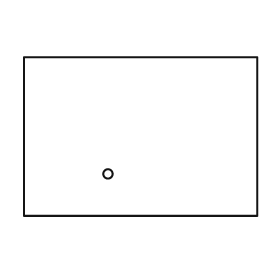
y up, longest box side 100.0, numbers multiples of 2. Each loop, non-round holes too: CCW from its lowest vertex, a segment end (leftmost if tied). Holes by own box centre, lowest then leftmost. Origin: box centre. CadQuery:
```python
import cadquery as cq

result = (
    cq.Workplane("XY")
    .moveTo(-50.0, -34.0)
    .lineTo(50.0, -34.0)
    .lineTo(50.0, 34.0)
    .lineTo(-50.0, 34.0)
    .close()
    .moveTo(-14.0, -16.0)
    .circle(2.0)
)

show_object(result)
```